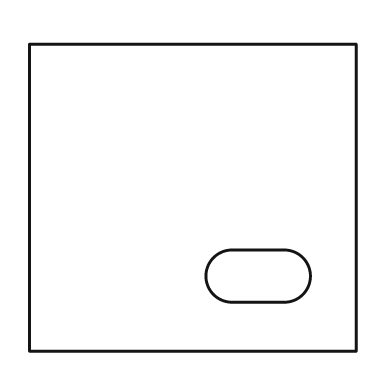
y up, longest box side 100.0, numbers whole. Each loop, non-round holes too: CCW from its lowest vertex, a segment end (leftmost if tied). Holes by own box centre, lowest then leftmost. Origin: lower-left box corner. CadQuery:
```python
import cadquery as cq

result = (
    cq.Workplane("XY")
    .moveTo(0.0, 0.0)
    .lineTo(100.0, 0.0)
    .lineTo(100.0, 94.0)
    .lineTo(0.0, 94.0)
    .close()
    .moveTo(62.0, 15.0)
    .lineTo(78.0, 15.0)
    .threePointArc((86.0, 23.0), (78.0, 31.0))
    .lineTo(62.0, 31.0)
    .threePointArc((54.0, 23.0), (62.0, 15.0))
    .close()
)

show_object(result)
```